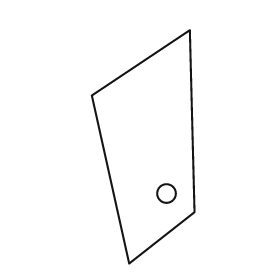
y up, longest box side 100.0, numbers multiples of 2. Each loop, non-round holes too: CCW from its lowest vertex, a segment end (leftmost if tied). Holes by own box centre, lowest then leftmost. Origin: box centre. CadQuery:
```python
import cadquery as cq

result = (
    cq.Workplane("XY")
    .moveTo(-6.0, -50.0)
    .lineTo(22.0, -28.0)
    .lineTo(20.0, 50.0)
    .lineTo(-22.0, 22.0)
    .close()
    .moveTo(10.0, -20.0)
    .circle(4.0)
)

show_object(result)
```